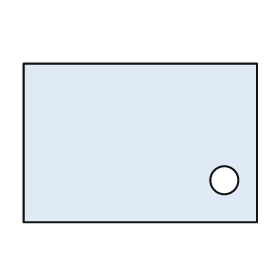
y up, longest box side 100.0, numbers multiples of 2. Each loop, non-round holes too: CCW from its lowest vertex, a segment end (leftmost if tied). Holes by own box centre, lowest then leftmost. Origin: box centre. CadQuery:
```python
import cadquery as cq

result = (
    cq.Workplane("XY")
    .moveTo(-50.0, -34.0)
    .lineTo(50.0, -34.0)
    .lineTo(50.0, 34.0)
    .lineTo(-50.0, 34.0)
    .close()
    .moveTo(36.0, -16.0)
    .circle(6.0)
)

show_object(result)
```